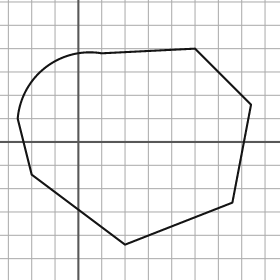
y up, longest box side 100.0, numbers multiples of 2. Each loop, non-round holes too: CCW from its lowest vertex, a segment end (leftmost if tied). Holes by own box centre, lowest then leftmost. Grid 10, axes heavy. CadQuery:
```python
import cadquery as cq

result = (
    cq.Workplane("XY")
    .moveTo(20.0, -44.0)
    .lineTo(66.0, -26.0)
    .lineTo(74.0, 16.0)
    .lineTo(50.0, 40.0)
    .lineTo(10.0, 38.0)
    .threePointArc((-14.0, 32.0), (-26.0, 10.0))
    .lineTo(-20.0, -14.0)
    .close()
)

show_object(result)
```